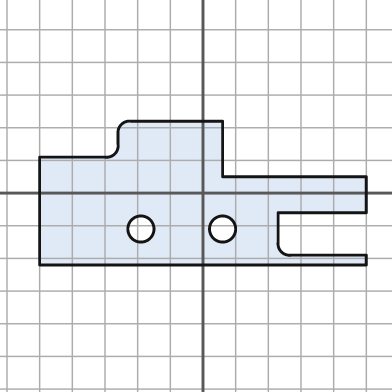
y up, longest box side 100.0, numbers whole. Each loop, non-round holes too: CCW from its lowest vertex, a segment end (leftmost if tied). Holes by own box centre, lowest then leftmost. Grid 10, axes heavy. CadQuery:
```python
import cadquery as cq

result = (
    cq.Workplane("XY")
    .moveTo(-50.0, -22.0)
    .lineTo(50.0, -22.0)
    .lineTo(50.0, -19.0)
    .lineTo(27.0, -19.0)
    .threePointArc((24.0, -18.0), (23.0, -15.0))
    .lineTo(23.0, -6.0)
    .lineTo(50.0, -6.0)
    .lineTo(50.0, 5.0)
    .lineTo(6.0, 5.0)
    .lineTo(6.0, 22.0)
    .lineTo(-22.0, 22.0)
    .threePointArc((-25.0, 21.0), (-26.0, 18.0))
    .lineTo(-26.0, 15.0)
    .threePointArc((-27.0, 12.0), (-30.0, 11.0))
    .lineTo(-50.0, 11.0)
    .close()
    .moveTo(-19.0, -11.0)
    .circle(4.0)
    .moveTo(6.0, -11.0)
    .circle(4.0)
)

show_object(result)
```